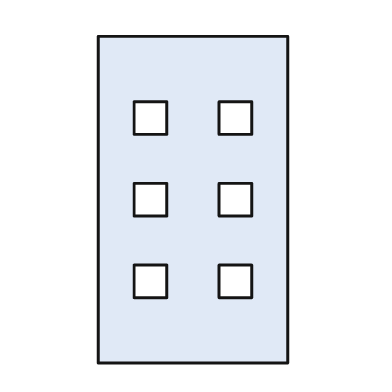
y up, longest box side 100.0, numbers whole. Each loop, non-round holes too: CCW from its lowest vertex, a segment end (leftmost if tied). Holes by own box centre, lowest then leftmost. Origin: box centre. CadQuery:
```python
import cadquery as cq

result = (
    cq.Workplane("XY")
    .moveTo(-29.0, -50.0)
    .lineTo(29.0, -50.0)
    .lineTo(29.0, 50.0)
    .lineTo(-29.0, 50.0)
    .close()
    .moveTo(-18.0, -30.0)
    .lineTo(-8.0, -30.0)
    .lineTo(-8.0, -20.0)
    .lineTo(-18.0, -20.0)
    .close()
    .moveTo(8.0, -30.0)
    .lineTo(18.0, -30.0)
    .lineTo(18.0, -20.0)
    .lineTo(8.0, -20.0)
    .close()
    .moveTo(-18.0, -5.0)
    .lineTo(-8.0, -5.0)
    .lineTo(-8.0, 5.0)
    .lineTo(-18.0, 5.0)
    .close()
    .moveTo(8.0, -5.0)
    .lineTo(18.0, -5.0)
    .lineTo(18.0, 5.0)
    .lineTo(8.0, 5.0)
    .close()
    .moveTo(-18.0, 20.0)
    .lineTo(-8.0, 20.0)
    .lineTo(-8.0, 30.0)
    .lineTo(-18.0, 30.0)
    .close()
    .moveTo(8.0, 20.0)
    .lineTo(18.0, 20.0)
    .lineTo(18.0, 30.0)
    .lineTo(8.0, 30.0)
    .close()
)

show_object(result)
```